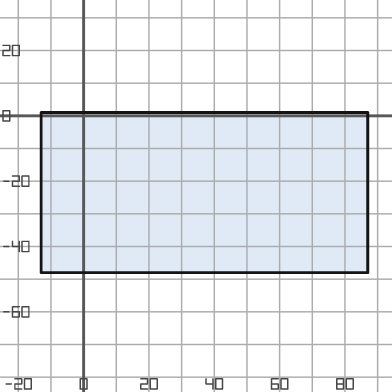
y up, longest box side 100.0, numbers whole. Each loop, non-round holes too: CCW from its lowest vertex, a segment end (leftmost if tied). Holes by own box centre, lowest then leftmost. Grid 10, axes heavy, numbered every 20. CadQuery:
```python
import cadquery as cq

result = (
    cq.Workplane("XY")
    .moveTo(-13.0, -48.0)
    .lineTo(87.0, -48.0)
    .lineTo(87.0, 1.0)
    .lineTo(-13.0, 1.0)
    .close()
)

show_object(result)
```